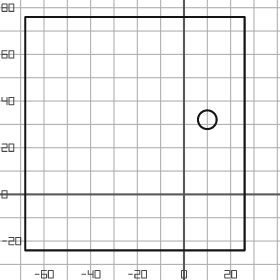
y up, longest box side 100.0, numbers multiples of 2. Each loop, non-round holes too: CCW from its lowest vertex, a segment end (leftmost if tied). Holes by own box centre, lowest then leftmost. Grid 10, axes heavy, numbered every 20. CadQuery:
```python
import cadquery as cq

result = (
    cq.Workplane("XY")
    .moveTo(-68.0, -24.0)
    .lineTo(26.0, -24.0)
    .lineTo(26.0, 76.0)
    .lineTo(-68.0, 76.0)
    .close()
    .moveTo(10.0, 32.0)
    .circle(4.0)
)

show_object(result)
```